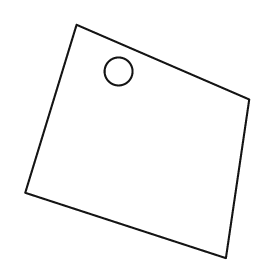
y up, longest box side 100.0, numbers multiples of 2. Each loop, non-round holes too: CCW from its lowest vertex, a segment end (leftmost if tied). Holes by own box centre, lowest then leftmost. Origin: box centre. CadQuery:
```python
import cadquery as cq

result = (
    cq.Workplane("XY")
    .moveTo(38.0, -50.0)
    .lineTo(48.0, 18.0)
    .lineTo(-26.0, 50.0)
    .lineTo(-48.0, -22.0)
    .close()
    .moveTo(-8.0, 30.0)
    .circle(6.0)
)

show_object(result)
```